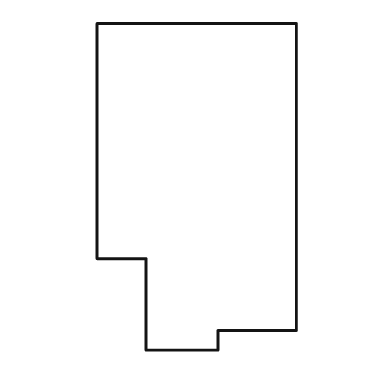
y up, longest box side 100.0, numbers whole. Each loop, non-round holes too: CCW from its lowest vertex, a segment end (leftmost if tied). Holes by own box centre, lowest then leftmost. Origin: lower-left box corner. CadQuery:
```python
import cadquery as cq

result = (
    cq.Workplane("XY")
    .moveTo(15.0, 0.0)
    .lineTo(37.0, 0.0)
    .lineTo(37.0, 6.0)
    .lineTo(61.0, 6.0)
    .lineTo(61.0, 100.0)
    .lineTo(0.0, 100.0)
    .lineTo(0.0, 28.0)
    .lineTo(15.0, 28.0)
    .close()
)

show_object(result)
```